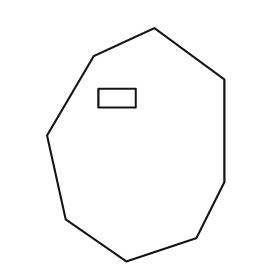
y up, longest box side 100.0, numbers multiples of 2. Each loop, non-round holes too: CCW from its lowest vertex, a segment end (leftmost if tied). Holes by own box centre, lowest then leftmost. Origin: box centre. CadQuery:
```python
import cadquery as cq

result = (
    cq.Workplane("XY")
    .moveTo(-4.0, -50.0)
    .lineTo(26.0, -40.0)
    .lineTo(38.0, -16.0)
    .lineTo(38.0, 28.0)
    .lineTo(8.0, 50.0)
    .lineTo(-18.0, 38.0)
    .lineTo(-38.0, 4.0)
    .lineTo(-30.0, -32.0)
    .close()
    .moveTo(-16.0, 16.0)
    .lineTo(0.0, 16.0)
    .lineTo(0.0, 24.0)
    .lineTo(-16.0, 24.0)
    .close()
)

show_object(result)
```